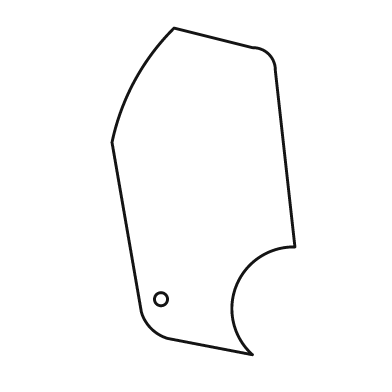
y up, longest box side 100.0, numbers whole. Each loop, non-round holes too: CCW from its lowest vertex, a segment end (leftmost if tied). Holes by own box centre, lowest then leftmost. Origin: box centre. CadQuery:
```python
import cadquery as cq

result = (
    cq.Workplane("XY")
    .moveTo(15.0, -50.0)
    .threePointArc((10.0, -29.0), (28.0, -17.0))
    .lineTo(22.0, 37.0)
    .threePointArc((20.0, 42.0), (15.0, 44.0))
    .lineTo(-9.0, 50.0)
    .threePointArc((-21.0, 34.0), (-28.0, 15.0))
    .lineTo(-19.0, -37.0)
    .threePointArc((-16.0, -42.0), (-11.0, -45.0))
    .close()
    .moveTo(-13.0, -33.0)
    .circle(2.0)
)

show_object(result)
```